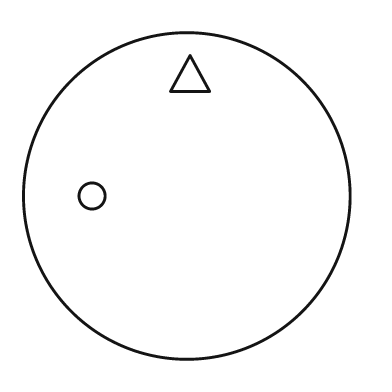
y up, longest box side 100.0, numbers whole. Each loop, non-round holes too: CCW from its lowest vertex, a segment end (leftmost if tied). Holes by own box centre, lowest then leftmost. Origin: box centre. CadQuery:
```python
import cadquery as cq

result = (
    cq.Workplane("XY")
    .moveTo(0.0, 0.0)
    .circle(50.0)
    .moveTo(-29.0, 0.0)
    .circle(4.0)
    .moveTo(-5.0, 32.0)
    .lineTo(7.0, 32.0)
    .lineTo(1.0, 43.0)
    .close()
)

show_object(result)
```